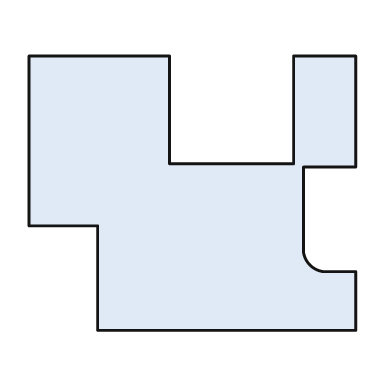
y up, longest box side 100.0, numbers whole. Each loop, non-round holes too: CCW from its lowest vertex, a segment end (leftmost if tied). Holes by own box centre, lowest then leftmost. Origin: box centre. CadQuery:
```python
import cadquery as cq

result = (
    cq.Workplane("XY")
    .moveTo(-29.0, -42.0)
    .lineTo(50.0, -42.0)
    .lineTo(50.0, -24.0)
    .lineTo(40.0, -24.0)
    .threePointArc((36.0, -22.0), (34.0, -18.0))
    .lineTo(34.0, 8.0)
    .lineTo(50.0, 8.0)
    .lineTo(50.0, 42.0)
    .lineTo(31.0, 42.0)
    .lineTo(31.0, 9.0)
    .lineTo(-7.0, 9.0)
    .lineTo(-7.0, 42.0)
    .lineTo(-50.0, 42.0)
    .lineTo(-50.0, -10.0)
    .lineTo(-29.0, -10.0)
    .close()
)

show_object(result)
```